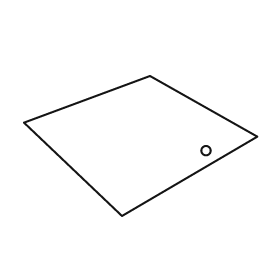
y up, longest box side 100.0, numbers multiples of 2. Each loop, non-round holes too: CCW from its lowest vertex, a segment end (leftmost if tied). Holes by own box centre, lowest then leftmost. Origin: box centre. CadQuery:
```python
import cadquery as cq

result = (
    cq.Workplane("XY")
    .moveTo(-8.0, -30.0)
    .lineTo(50.0, 4.0)
    .lineTo(4.0, 30.0)
    .lineTo(-50.0, 10.0)
    .close()
    .moveTo(28.0, -2.0)
    .circle(2.0)
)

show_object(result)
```